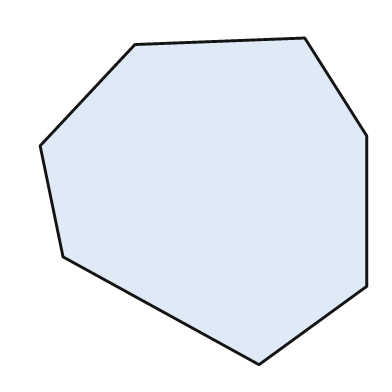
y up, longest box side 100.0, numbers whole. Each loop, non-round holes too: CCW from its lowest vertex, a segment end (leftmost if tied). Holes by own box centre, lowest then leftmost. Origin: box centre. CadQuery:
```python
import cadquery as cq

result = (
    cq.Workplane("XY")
    .moveTo(17.0, -50.0)
    .lineTo(50.0, -26.0)
    .lineTo(50.0, 20.0)
    .lineTo(31.0, 50.0)
    .lineTo(-21.0, 48.0)
    .lineTo(-50.0, 17.0)
    .lineTo(-43.0, -17.0)
    .close()
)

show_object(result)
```